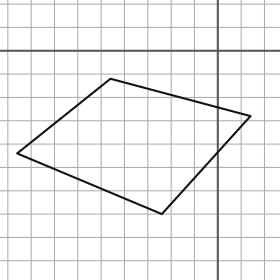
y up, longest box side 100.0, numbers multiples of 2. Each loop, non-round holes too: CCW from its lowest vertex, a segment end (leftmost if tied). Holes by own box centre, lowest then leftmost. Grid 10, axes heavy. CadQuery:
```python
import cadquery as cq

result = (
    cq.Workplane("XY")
    .moveTo(-24.0, -70.0)
    .lineTo(14.0, -28.0)
    .lineTo(-46.0, -12.0)
    .lineTo(-86.0, -44.0)
    .close()
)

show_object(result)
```